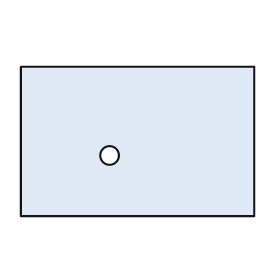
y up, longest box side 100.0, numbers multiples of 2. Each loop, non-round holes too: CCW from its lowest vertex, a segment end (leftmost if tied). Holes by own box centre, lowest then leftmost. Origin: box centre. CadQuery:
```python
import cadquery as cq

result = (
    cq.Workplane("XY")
    .moveTo(-50.0, -32.0)
    .lineTo(50.0, -32.0)
    .lineTo(50.0, 32.0)
    .lineTo(-50.0, 32.0)
    .close()
    .moveTo(-12.0, -6.0)
    .circle(4.0)
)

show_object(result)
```